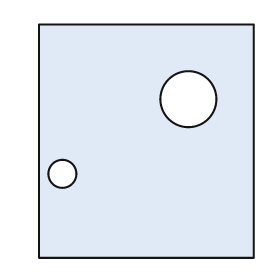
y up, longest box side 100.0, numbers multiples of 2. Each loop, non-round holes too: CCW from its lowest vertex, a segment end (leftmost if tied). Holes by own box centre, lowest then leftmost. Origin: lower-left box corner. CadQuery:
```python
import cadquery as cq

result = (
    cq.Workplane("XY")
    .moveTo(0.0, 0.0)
    .lineTo(92.0, 0.0)
    .lineTo(92.0, 100.0)
    .lineTo(0.0, 100.0)
    .close()
    .moveTo(10.0, 36.0)
    .circle(6.0)
    .moveTo(64.0, 68.0)
    .circle(12.0)
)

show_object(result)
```